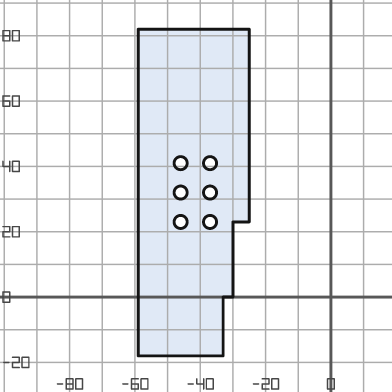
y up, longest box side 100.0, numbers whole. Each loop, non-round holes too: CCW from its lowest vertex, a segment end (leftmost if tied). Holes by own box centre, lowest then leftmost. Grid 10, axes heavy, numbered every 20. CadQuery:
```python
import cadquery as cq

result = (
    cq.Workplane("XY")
    .moveTo(-59.0, -18.0)
    .lineTo(-33.0, -18.0)
    .lineTo(-33.0, 0.0)
    .lineTo(-30.0, 0.0)
    .lineTo(-30.0, 23.0)
    .lineTo(-25.0, 23.0)
    .lineTo(-25.0, 82.0)
    .lineTo(-59.0, 82.0)
    .close()
    .moveTo(-46.0, 23.0)
    .circle(2.0)
    .moveTo(-37.0, 23.0)
    .circle(2.0)
    .moveTo(-46.0, 32.0)
    .circle(2.0)
    .moveTo(-37.0, 32.0)
    .circle(2.0)
    .moveTo(-46.0, 41.0)
    .circle(2.0)
    .moveTo(-37.0, 41.0)
    .circle(2.0)
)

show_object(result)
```